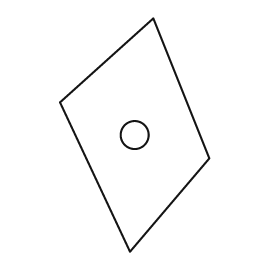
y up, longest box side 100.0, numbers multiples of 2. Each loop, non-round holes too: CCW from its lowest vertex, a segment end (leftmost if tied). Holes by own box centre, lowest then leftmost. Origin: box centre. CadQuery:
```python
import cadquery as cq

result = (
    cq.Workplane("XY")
    .moveTo(-2.0, -50.0)
    .lineTo(32.0, -10.0)
    .lineTo(8.0, 50.0)
    .lineTo(-32.0, 14.0)
    .close()
    .moveTo(0.0, 0.0)
    .circle(6.0)
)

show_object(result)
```